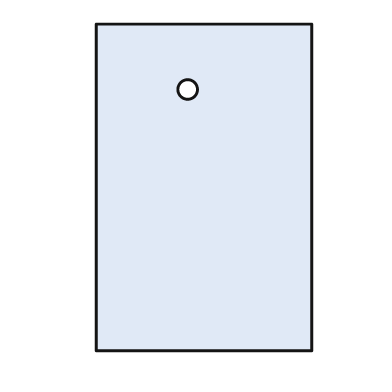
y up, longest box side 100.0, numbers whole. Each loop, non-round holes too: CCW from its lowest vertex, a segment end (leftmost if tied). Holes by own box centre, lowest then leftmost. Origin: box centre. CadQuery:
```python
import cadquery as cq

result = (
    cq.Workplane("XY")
    .moveTo(-33.0, -50.0)
    .lineTo(33.0, -50.0)
    .lineTo(33.0, 50.0)
    .lineTo(-33.0, 50.0)
    .close()
    .moveTo(-5.0, 30.0)
    .circle(3.0)
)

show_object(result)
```